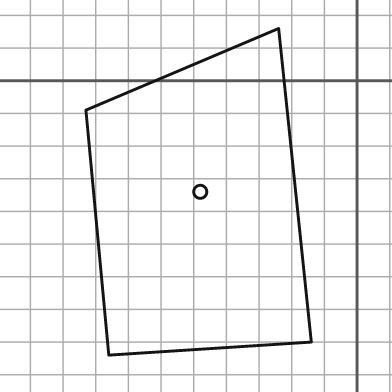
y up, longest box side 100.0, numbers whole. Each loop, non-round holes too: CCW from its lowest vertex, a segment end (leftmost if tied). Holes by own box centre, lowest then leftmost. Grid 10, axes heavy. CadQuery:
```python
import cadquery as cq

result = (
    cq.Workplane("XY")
    .moveTo(-76.0, -84.0)
    .lineTo(-14.0, -80.0)
    .lineTo(-24.0, 16.0)
    .lineTo(-83.0, -9.0)
    .close()
    .moveTo(-48.0, -34.0)
    .circle(2.0)
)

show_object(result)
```